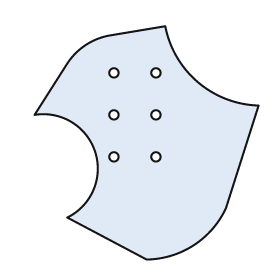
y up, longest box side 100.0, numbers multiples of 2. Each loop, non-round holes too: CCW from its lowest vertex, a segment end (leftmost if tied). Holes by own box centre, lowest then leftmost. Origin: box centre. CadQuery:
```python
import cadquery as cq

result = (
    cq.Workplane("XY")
    .moveTo(0.0, -50.0)
    .threePointArc((20.0, -44.0), (34.0, -28.0))
    .lineTo(48.0, 16.0)
    .threePointArc((22.0, 26.0), (8.0, 50.0))
    .lineTo(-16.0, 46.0)
    .threePointArc((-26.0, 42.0), (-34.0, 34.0))
    .lineTo(-48.0, 12.0)
    .threePointArc((-22.0, -4.0), (-34.0, -32.0))
    .close()
    .moveTo(-14.0, -6.0)
    .circle(2.0)
    .moveTo(4.0, -6.0)
    .circle(2.0)
    .moveTo(-14.0, 12.0)
    .circle(2.0)
    .moveTo(4.0, 12.0)
    .circle(2.0)
    .moveTo(-14.0, 30.0)
    .circle(2.0)
    .moveTo(4.0, 30.0)
    .circle(2.0)
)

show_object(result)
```